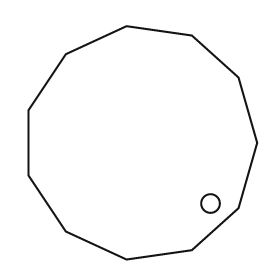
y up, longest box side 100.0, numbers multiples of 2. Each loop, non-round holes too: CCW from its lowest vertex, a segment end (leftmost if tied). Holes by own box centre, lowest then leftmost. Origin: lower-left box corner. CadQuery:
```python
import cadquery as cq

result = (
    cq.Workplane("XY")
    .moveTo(42.0, 0.0)
    .lineTo(70.0, 4.0)
    .lineTo(90.0, 22.0)
    .lineTo(98.0, 50.0)
    .lineTo(90.0, 78.0)
    .lineTo(70.0, 96.0)
    .lineTo(42.0, 100.0)
    .lineTo(16.0, 88.0)
    .lineTo(0.0, 64.0)
    .lineTo(0.0, 36.0)
    .lineTo(16.0, 12.0)
    .close()
    .moveTo(78.0, 24.0)
    .circle(4.0)
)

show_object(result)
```